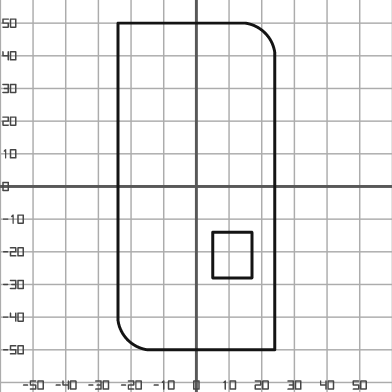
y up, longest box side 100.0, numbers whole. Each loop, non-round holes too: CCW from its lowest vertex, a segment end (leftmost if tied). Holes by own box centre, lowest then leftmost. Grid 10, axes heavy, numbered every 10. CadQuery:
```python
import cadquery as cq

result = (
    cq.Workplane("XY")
    .moveTo(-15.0, -50.0)
    .lineTo(24.0, -50.0)
    .lineTo(24.0, 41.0)
    .threePointArc((21.0, 47.0), (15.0, 50.0))
    .lineTo(-24.0, 50.0)
    .lineTo(-24.0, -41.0)
    .threePointArc((-21.0, -47.0), (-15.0, -50.0))
    .close()
    .moveTo(5.0, -28.0)
    .lineTo(17.0, -28.0)
    .lineTo(17.0, -14.0)
    .lineTo(5.0, -14.0)
    .close()
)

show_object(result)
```